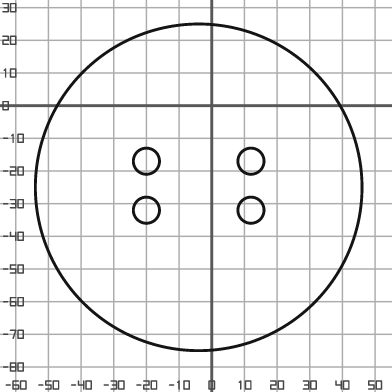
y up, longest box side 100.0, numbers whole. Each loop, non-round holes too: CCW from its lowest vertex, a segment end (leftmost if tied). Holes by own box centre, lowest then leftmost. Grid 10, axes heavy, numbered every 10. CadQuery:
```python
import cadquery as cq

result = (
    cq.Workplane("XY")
    .moveTo(-4.0, -25.0)
    .circle(50.0)
    .moveTo(-20.0, -32.0)
    .circle(4.0)
    .moveTo(12.0, -32.0)
    .circle(4.0)
    .moveTo(-20.0, -17.0)
    .circle(4.0)
    .moveTo(12.0, -17.0)
    .circle(4.0)
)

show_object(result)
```